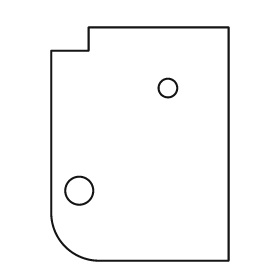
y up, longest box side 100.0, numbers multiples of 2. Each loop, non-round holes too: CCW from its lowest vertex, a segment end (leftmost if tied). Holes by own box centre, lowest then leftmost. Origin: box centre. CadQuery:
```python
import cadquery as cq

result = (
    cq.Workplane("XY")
    .moveTo(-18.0, -50.0)
    .lineTo(38.0, -50.0)
    .lineTo(38.0, 50.0)
    .lineTo(-22.0, 50.0)
    .lineTo(-22.0, 40.0)
    .lineTo(-38.0, 40.0)
    .lineTo(-38.0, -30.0)
    .threePointArc((-32.0, -44.0), (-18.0, -50.0))
    .close()
    .moveTo(-26.0, -20.0)
    .circle(6.0)
    .moveTo(12.0, 24.0)
    .circle(4.0)
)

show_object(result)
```